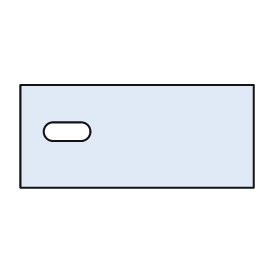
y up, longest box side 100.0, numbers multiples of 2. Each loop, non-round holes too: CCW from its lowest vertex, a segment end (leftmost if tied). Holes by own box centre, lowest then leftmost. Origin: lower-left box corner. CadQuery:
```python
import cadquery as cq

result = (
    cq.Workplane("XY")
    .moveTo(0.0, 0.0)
    .lineTo(100.0, 0.0)
    .lineTo(100.0, 44.0)
    .lineTo(0.0, 44.0)
    .close()
    .moveTo(14.0, 20.0)
    .lineTo(26.0, 20.0)
    .threePointArc((30.0, 24.0), (26.0, 28.0))
    .lineTo(14.0, 28.0)
    .threePointArc((10.0, 24.0), (14.0, 20.0))
    .close()
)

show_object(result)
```